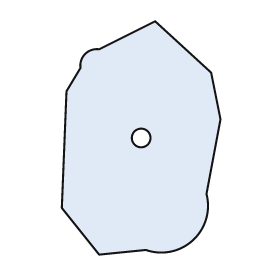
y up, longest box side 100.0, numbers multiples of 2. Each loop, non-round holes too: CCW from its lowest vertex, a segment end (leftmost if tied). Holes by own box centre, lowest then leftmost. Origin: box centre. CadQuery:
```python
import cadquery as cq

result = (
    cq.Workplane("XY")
    .moveTo(-18.0, -50.0)
    .lineTo(2.0, -48.0)
    .threePointArc((22.0, -44.0), (28.0, -24.0))
    .lineTo(34.0, 8.0)
    .lineTo(30.0, 28.0)
    .lineTo(6.0, 50.0)
    .lineTo(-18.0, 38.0)
    .threePointArc((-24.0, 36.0), (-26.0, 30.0))
    .lineTo(-32.0, 20.0)
    .lineTo(-34.0, -30.0)
    .close()
    .moveTo(0.0, 0.0)
    .circle(4.0)
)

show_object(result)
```